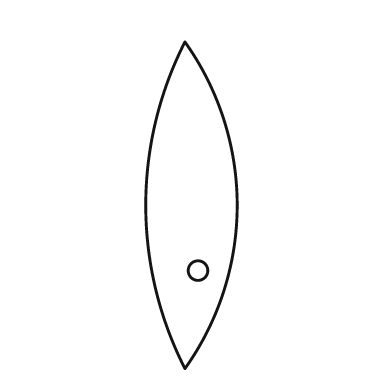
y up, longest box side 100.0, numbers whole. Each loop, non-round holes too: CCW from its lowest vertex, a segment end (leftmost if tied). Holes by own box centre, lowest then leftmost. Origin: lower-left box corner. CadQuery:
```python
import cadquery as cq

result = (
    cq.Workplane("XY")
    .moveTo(12.0, 0.0)
    .threePointArc((28.0, 50.0), (12.0, 100.0))
    .threePointArc((0.0, 50.0), (12.0, 0.0))
    .close()
    .moveTo(16.0, 30.0)
    .circle(3.0)
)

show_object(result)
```